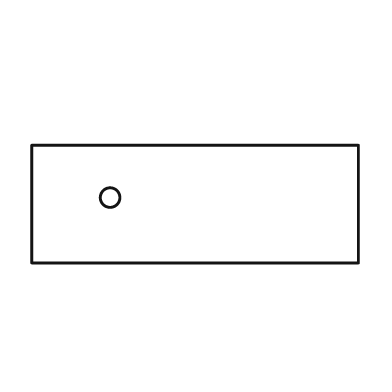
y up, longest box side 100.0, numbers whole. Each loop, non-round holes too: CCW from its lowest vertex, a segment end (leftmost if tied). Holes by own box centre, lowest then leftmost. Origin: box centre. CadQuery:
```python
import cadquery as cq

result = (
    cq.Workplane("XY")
    .moveTo(-50.0, -18.0)
    .lineTo(50.0, -18.0)
    .lineTo(50.0, 18.0)
    .lineTo(-50.0, 18.0)
    .close()
    .moveTo(-26.0, 2.0)
    .circle(3.0)
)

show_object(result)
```